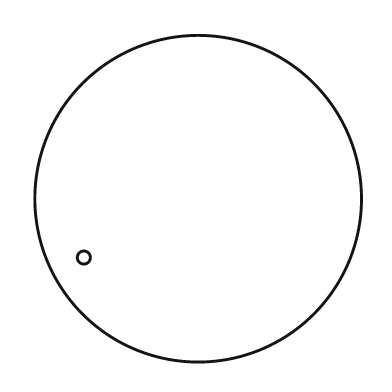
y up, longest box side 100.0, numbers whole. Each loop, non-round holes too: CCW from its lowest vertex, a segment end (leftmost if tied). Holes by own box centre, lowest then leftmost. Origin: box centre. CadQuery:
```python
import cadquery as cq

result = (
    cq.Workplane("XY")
    .moveTo(0.0, 0.0)
    .circle(50.0)
    .moveTo(-35.0, -18.0)
    .circle(2.0)
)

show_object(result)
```